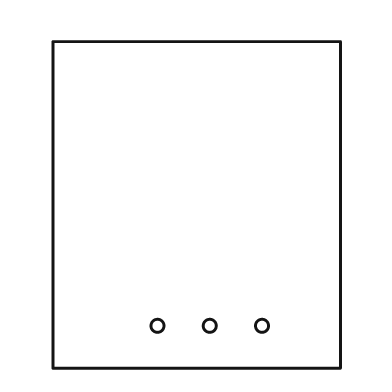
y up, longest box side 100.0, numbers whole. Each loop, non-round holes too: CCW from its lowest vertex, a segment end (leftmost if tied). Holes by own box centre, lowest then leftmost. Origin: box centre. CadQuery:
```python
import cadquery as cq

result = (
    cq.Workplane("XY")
    .moveTo(-44.0, -50.0)
    .lineTo(44.0, -50.0)
    .lineTo(44.0, 50.0)
    .lineTo(-44.0, 50.0)
    .close()
    .moveTo(-12.0, -37.0)
    .circle(2.0)
    .moveTo(4.0, -37.0)
    .circle(2.0)
    .moveTo(20.0, -37.0)
    .circle(2.0)
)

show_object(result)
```